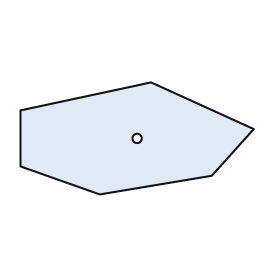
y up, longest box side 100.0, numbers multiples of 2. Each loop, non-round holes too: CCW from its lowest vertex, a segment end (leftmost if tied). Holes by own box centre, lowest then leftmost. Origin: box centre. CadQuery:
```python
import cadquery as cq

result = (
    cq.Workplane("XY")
    .moveTo(-16.0, -24.0)
    .lineTo(32.0, -16.0)
    .lineTo(50.0, 4.0)
    .lineTo(6.0, 24.0)
    .lineTo(-50.0, 12.0)
    .lineTo(-50.0, -12.0)
    .close()
    .moveTo(0.0, 0.0)
    .circle(2.0)
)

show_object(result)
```